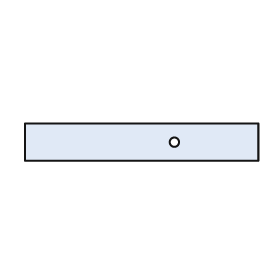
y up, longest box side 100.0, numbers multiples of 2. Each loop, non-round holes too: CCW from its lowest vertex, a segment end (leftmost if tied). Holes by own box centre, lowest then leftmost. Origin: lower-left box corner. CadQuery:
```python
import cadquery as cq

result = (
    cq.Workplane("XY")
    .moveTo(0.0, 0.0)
    .lineTo(100.0, 0.0)
    .lineTo(100.0, 16.0)
    .lineTo(0.0, 16.0)
    .close()
    .moveTo(64.0, 8.0)
    .circle(2.0)
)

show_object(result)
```